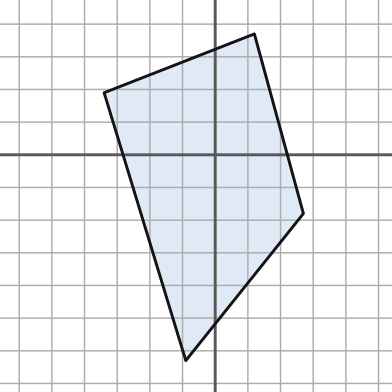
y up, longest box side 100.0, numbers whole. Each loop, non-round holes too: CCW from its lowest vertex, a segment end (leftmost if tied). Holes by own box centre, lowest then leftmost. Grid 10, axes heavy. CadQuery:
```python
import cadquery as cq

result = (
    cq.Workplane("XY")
    .moveTo(-9.0, -63.0)
    .lineTo(27.0, -18.0)
    .lineTo(12.0, 37.0)
    .lineTo(-34.0, 19.0)
    .close()
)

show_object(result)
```